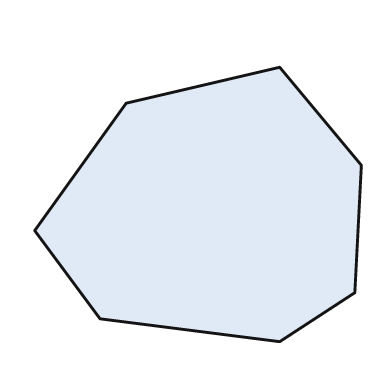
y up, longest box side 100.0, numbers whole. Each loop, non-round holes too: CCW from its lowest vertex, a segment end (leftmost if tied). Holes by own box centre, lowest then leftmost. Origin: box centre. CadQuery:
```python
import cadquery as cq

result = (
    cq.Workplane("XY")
    .moveTo(25.0, -42.0)
    .lineTo(48.0, -27.0)
    .lineTo(50.0, 12.0)
    .lineTo(25.0, 42.0)
    .lineTo(-22.0, 31.0)
    .lineTo(-50.0, -8.0)
    .lineTo(-30.0, -35.0)
    .close()
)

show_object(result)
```